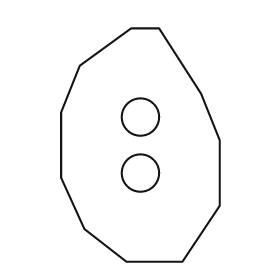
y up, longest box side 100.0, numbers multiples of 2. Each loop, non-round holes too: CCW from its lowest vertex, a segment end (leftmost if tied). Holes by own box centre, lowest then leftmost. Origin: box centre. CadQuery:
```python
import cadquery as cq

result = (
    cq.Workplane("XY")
    .moveTo(-6.0, -50.0)
    .lineTo(18.0, -50.0)
    .lineTo(34.0, -26.0)
    .lineTo(34.0, 2.0)
    .lineTo(26.0, 22.0)
    .lineTo(8.0, 50.0)
    .lineTo(-4.0, 50.0)
    .lineTo(-26.0, 34.0)
    .lineTo(-34.0, 14.0)
    .lineTo(-34.0, -14.0)
    .lineTo(-24.0, -36.0)
    .close()
    .moveTo(0.0, -12.0)
    .circle(8.0)
    .moveTo(0.0, 12.0)
    .circle(8.0)
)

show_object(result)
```